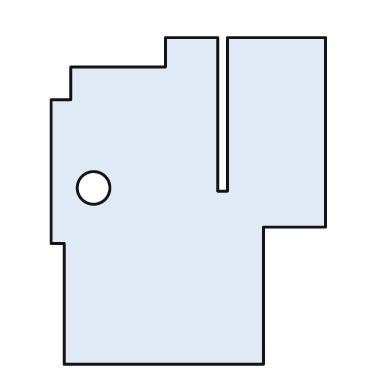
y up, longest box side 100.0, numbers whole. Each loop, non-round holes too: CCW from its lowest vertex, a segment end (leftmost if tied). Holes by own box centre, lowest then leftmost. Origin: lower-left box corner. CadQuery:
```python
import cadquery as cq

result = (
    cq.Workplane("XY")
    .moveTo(4.0, 0.0)
    .lineTo(65.0, 0.0)
    .lineTo(65.0, 42.0)
    .lineTo(84.0, 42.0)
    .lineTo(84.0, 100.0)
    .lineTo(54.0, 100.0)
    .lineTo(54.0, 53.0)
    .lineTo(51.0, 53.0)
    .lineTo(51.0, 100.0)
    .lineTo(35.0, 100.0)
    .lineTo(35.0, 91.0)
    .lineTo(6.0, 91.0)
    .lineTo(6.0, 81.0)
    .lineTo(0.0, 81.0)
    .lineTo(0.0, 37.0)
    .lineTo(4.0, 37.0)
    .close()
    .moveTo(13.0, 54.0)
    .circle(5.0)
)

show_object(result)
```